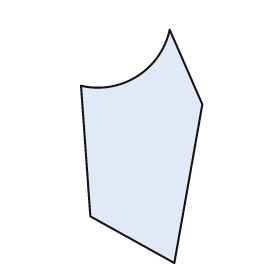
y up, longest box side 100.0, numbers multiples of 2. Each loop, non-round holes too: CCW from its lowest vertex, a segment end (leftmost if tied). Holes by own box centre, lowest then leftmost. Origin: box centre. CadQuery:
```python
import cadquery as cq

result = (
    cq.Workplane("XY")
    .moveTo(14.0, -50.0)
    .lineTo(26.0, 18.0)
    .lineTo(12.0, 50.0)
    .threePointArc((-2.0, 30.0), (-26.0, 26.0))
    .lineTo(-22.0, -30.0)
    .close()
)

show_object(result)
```